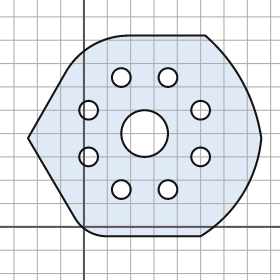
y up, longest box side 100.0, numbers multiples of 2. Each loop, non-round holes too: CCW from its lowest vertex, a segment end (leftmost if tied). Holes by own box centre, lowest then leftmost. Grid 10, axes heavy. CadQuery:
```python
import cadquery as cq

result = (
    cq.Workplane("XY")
    .moveTo(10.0, -4.0)
    .lineTo(50.0, -4.0)
    .threePointArc((68.0, 14.0), (76.0, 38.0))
    .threePointArc((68.0, 62.0), (52.0, 82.0))
    .lineTo(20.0, 82.0)
    .threePointArc((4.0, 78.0), (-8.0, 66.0))
    .lineTo(-24.0, 38.0)
    .lineTo(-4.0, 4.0)
    .threePointArc((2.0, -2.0), (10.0, -4.0))
    .close()
    .moveTo(16.0, 16.0)
    .circle(4.0)
    .moveTo(36.0, 16.0)
    .circle(4.0)
    .moveTo(2.0, 30.0)
    .circle(4.0)
    .moveTo(50.0, 30.0)
    .circle(4.0)
    .moveTo(26.0, 40.0)
    .circle(10.0)
    .moveTo(2.0, 50.0)
    .circle(4.0)
    .moveTo(50.0, 50.0)
    .circle(4.0)
    .moveTo(16.0, 64.0)
    .circle(4.0)
    .moveTo(36.0, 64.0)
    .circle(4.0)
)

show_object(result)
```